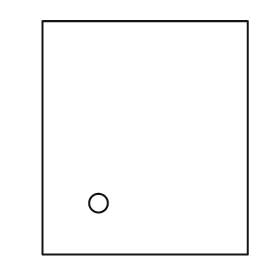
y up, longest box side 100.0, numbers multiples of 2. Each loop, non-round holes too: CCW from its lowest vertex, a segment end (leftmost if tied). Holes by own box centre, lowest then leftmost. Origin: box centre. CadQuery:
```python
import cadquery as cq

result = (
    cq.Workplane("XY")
    .moveTo(-44.0, -50.0)
    .lineTo(44.0, -50.0)
    .lineTo(44.0, 50.0)
    .lineTo(-44.0, 50.0)
    .close()
    .moveTo(-20.0, -28.0)
    .circle(4.0)
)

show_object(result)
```